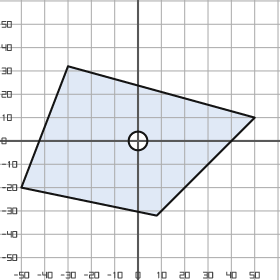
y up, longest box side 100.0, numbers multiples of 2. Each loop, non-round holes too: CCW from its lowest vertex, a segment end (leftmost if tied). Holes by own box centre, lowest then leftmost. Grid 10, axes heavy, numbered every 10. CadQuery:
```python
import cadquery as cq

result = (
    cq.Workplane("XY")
    .moveTo(8.0, -32.0)
    .lineTo(50.0, 10.0)
    .lineTo(-30.0, 32.0)
    .lineTo(-50.0, -20.0)
    .close()
    .moveTo(0.0, 0.0)
    .circle(4.0)
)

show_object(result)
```